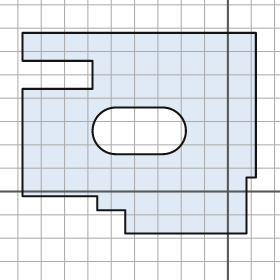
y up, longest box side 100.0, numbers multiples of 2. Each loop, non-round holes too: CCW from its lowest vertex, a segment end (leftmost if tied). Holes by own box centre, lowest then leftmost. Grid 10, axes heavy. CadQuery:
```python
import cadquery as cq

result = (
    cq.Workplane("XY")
    .moveTo(-44.0, -18.0)
    .lineTo(8.0, -18.0)
    .lineTo(8.0, 6.0)
    .lineTo(12.0, 6.0)
    .lineTo(12.0, 68.0)
    .lineTo(-88.0, 68.0)
    .lineTo(-88.0, 56.0)
    .lineTo(-58.0, 56.0)
    .lineTo(-58.0, 44.0)
    .lineTo(-88.0, 44.0)
    .lineTo(-88.0, -2.0)
    .lineTo(-56.0, -2.0)
    .lineTo(-56.0, -8.0)
    .lineTo(-44.0, -8.0)
    .close()
    .moveTo(-48.0, 16.0)
    .lineTo(-28.0, 16.0)
    .threePointArc((-18.0, 26.0), (-28.0, 36.0))
    .lineTo(-48.0, 36.0)
    .threePointArc((-58.0, 26.0), (-48.0, 16.0))
    .close()
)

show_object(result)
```